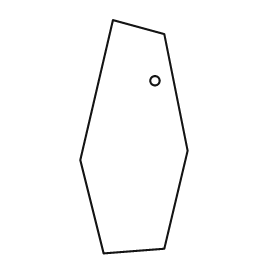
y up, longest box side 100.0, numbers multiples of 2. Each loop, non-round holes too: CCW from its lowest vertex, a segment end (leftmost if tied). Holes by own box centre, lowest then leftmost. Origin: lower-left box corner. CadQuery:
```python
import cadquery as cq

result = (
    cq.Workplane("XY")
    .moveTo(10.0, 0.0)
    .lineTo(36.0, 2.0)
    .lineTo(46.0, 44.0)
    .lineTo(36.0, 94.0)
    .lineTo(14.0, 100.0)
    .lineTo(0.0, 40.0)
    .close()
    .moveTo(32.0, 74.0)
    .circle(2.0)
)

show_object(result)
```